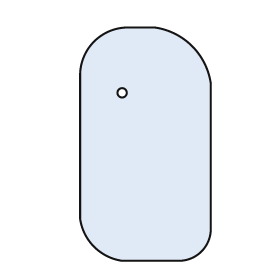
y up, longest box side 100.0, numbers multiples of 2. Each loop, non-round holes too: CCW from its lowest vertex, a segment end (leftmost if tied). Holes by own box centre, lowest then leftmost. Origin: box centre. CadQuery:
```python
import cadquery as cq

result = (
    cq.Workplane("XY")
    .moveTo(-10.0, -50.0)
    .lineTo(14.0, -50.0)
    .threePointArc((24.0, -46.0), (28.0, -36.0))
    .lineTo(28.0, 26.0)
    .threePointArc((20.0, 42.0), (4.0, 50.0))
    .lineTo(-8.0, 50.0)
    .threePointArc((-22.0, 44.0), (-28.0, 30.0))
    .lineTo(-28.0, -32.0)
    .threePointArc((-22.0, -44.0), (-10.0, -50.0))
    .close()
    .moveTo(-10.0, 22.0)
    .circle(2.0)
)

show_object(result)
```